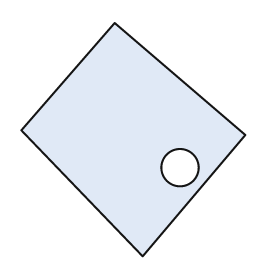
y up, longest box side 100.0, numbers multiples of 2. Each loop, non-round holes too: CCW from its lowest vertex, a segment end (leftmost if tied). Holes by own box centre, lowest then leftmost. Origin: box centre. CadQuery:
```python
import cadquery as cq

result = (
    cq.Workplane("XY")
    .moveTo(4.0, -50.0)
    .lineTo(48.0, 2.0)
    .lineTo(-8.0, 50.0)
    .lineTo(-48.0, 4.0)
    .close()
    .moveTo(20.0, -12.0)
    .circle(8.0)
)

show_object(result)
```